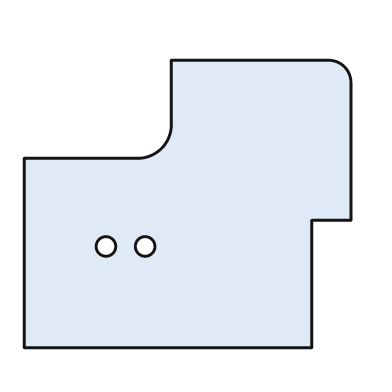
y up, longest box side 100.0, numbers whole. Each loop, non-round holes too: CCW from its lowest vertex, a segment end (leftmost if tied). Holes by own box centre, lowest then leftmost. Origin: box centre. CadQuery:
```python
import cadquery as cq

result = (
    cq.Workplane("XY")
    .moveTo(-50.0, -44.0)
    .lineTo(38.0, -44.0)
    .lineTo(38.0, -5.0)
    .lineTo(50.0, -5.0)
    .lineTo(50.0, 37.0)
    .threePointArc((48.0, 42.0), (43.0, 44.0))
    .lineTo(-5.0, 44.0)
    .lineTo(-5.0, 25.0)
    .threePointArc((-8.0, 17.0), (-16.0, 14.0))
    .lineTo(-50.0, 14.0)
    .close()
    .moveTo(-25.0, -13.0)
    .circle(3.0)
    .moveTo(-13.0, -13.0)
    .circle(3.0)
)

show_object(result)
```